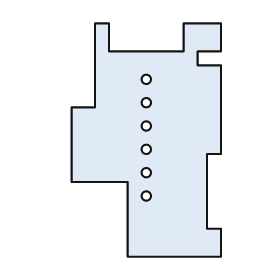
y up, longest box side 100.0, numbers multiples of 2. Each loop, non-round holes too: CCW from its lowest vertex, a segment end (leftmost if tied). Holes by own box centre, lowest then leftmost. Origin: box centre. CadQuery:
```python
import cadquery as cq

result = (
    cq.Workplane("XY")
    .moveTo(-8.0, -50.0)
    .lineTo(32.0, -50.0)
    .lineTo(32.0, -38.0)
    .lineTo(26.0, -38.0)
    .lineTo(26.0, -6.0)
    .lineTo(32.0, -6.0)
    .lineTo(32.0, 32.0)
    .lineTo(22.0, 32.0)
    .lineTo(22.0, 38.0)
    .lineTo(32.0, 38.0)
    .lineTo(32.0, 50.0)
    .lineTo(16.0, 50.0)
    .lineTo(16.0, 38.0)
    .lineTo(-16.0, 38.0)
    .lineTo(-16.0, 50.0)
    .lineTo(-22.0, 50.0)
    .lineTo(-22.0, 14.0)
    .lineTo(-32.0, 14.0)
    .lineTo(-32.0, -18.0)
    .lineTo(-8.0, -18.0)
    .close()
    .moveTo(0.0, -24.0)
    .circle(2.0)
    .moveTo(0.0, -14.0)
    .circle(2.0)
    .moveTo(0.0, -4.0)
    .circle(2.0)
    .moveTo(0.0, 6.0)
    .circle(2.0)
    .moveTo(0.0, 16.0)
    .circle(2.0)
    .moveTo(0.0, 26.0)
    .circle(2.0)
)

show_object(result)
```